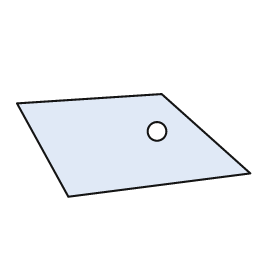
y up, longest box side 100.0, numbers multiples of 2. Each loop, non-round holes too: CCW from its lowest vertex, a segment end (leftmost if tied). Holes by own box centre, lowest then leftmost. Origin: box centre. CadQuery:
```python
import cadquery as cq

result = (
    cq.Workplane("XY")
    .moveTo(-28.0, -22.0)
    .lineTo(50.0, -12.0)
    .lineTo(12.0, 22.0)
    .lineTo(-50.0, 18.0)
    .close()
    .moveTo(10.0, 6.0)
    .circle(4.0)
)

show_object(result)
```